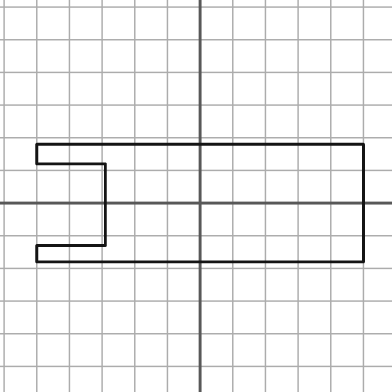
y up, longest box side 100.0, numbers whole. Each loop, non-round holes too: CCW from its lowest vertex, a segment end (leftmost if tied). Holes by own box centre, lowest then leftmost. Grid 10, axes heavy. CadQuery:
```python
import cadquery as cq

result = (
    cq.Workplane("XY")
    .moveTo(-50.0, -18.0)
    .lineTo(50.0, -18.0)
    .lineTo(50.0, 18.0)
    .lineTo(-50.0, 18.0)
    .lineTo(-50.0, 12.0)
    .lineTo(-29.0, 12.0)
    .lineTo(-29.0, -13.0)
    .lineTo(-50.0, -13.0)
    .close()
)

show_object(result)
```